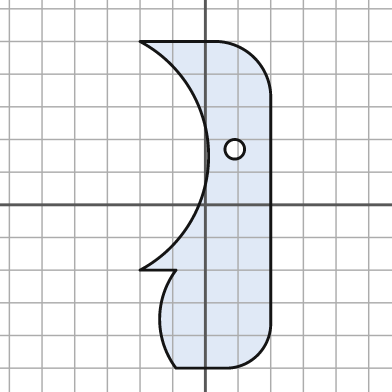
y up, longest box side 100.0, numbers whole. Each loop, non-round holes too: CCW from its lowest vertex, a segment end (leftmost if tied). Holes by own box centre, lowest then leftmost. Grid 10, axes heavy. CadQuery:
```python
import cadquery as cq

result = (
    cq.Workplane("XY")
    .moveTo(-9.0, -50.0)
    .lineTo(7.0, -50.0)
    .threePointArc((16.0, -46.0), (20.0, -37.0))
    .lineTo(20.0, 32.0)
    .threePointArc((15.0, 45.0), (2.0, 50.0))
    .lineTo(-20.0, 50.0)
    .threePointArc((1.0, 15.0), (-20.0, -20.0))
    .lineTo(-9.0, -20.0)
    .threePointArc((-14.0, -35.0), (-9.0, -50.0))
    .close()
    .moveTo(9.0, 17.0)
    .circle(3.0)
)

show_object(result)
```